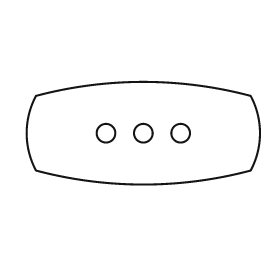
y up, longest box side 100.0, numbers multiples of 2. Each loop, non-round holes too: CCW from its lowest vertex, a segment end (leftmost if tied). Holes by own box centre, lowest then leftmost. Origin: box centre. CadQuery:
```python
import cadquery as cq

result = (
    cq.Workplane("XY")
    .moveTo(-46.0, -16.0)
    .threePointArc((0.0, -22.0), (46.0, -16.0))
    .threePointArc((50.0, 0.0), (46.0, 16.0))
    .threePointArc((0.0, 22.0), (-46.0, 16.0))
    .threePointArc((-50.0, 0.0), (-46.0, -16.0))
    .close()
    .moveTo(-16.0, 0.0)
    .circle(4.0)
    .moveTo(0.0, 0.0)
    .circle(4.0)
    .moveTo(16.0, 0.0)
    .circle(4.0)
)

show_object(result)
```